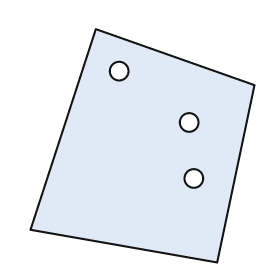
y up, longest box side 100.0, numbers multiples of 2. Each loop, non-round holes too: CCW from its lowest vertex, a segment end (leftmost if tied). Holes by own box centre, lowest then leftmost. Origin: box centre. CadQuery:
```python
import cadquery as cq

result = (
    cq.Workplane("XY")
    .moveTo(32.0, -50.0)
    .lineTo(48.0, 26.0)
    .lineTo(-20.0, 50.0)
    .lineTo(-48.0, -36.0)
    .close()
    .moveTo(22.0, -14.0)
    .circle(4.0)
    .moveTo(20.0, 10.0)
    .circle(4.0)
    .moveTo(-10.0, 32.0)
    .circle(4.0)
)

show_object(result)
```